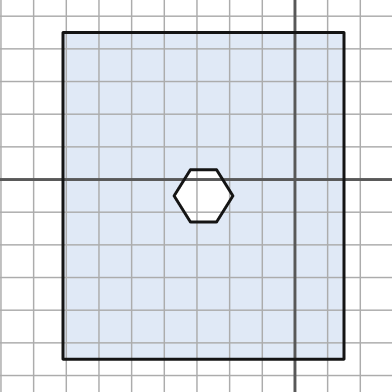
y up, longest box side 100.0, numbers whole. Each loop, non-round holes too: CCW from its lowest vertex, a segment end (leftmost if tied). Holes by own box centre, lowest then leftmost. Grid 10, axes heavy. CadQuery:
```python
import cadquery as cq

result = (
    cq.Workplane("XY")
    .moveTo(-71.0, -55.0)
    .lineTo(15.0, -55.0)
    .lineTo(15.0, 45.0)
    .lineTo(-71.0, 45.0)
    .close()
    .moveTo(-32.0, -13.0)
    .lineTo(-24.0, -13.0)
    .lineTo(-19.0, -5.0)
    .lineTo(-24.0, 3.0)
    .lineTo(-32.0, 3.0)
    .lineTo(-37.0, -5.0)
    .close()
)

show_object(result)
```